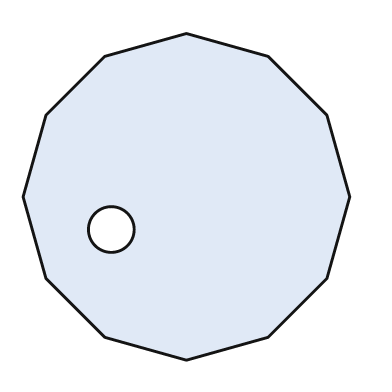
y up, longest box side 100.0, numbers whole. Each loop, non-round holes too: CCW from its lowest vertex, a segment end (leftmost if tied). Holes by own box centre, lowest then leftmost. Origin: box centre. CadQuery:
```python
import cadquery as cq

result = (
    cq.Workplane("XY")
    .moveTo(0.0, -50.0)
    .lineTo(25.0, -43.0)
    .lineTo(43.0, -25.0)
    .lineTo(50.0, 0.0)
    .lineTo(43.0, 25.0)
    .lineTo(25.0, 43.0)
    .lineTo(0.0, 50.0)
    .lineTo(-25.0, 43.0)
    .lineTo(-43.0, 25.0)
    .lineTo(-50.0, 0.0)
    .lineTo(-43.0, -25.0)
    .lineTo(-25.0, -43.0)
    .close()
    .moveTo(-23.0, -10.0)
    .circle(7.0)
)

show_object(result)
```